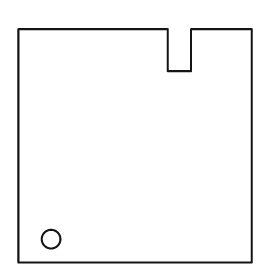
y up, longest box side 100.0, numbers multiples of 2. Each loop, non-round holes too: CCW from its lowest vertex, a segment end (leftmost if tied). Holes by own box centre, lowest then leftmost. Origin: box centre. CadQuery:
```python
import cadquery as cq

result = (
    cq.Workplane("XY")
    .moveTo(-50.0, -50.0)
    .lineTo(50.0, -50.0)
    .lineTo(50.0, 50.0)
    .lineTo(24.0, 50.0)
    .lineTo(24.0, 32.0)
    .lineTo(14.0, 32.0)
    .lineTo(14.0, 50.0)
    .lineTo(-50.0, 50.0)
    .close()
    .moveTo(-36.0, -40.0)
    .circle(4.0)
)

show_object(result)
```